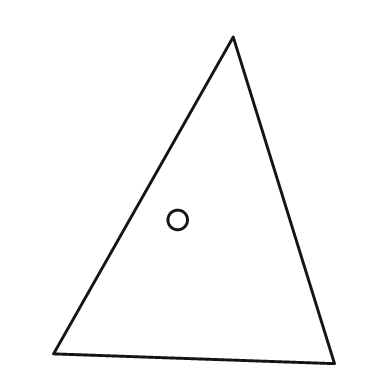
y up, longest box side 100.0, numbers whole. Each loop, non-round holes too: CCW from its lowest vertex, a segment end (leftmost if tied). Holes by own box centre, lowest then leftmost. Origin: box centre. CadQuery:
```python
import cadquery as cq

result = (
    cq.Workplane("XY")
    .moveTo(43.0, -50.0)
    .lineTo(12.0, 50.0)
    .lineTo(-43.0, -47.0)
    .close()
    .moveTo(-5.0, -6.0)
    .circle(3.0)
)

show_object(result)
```